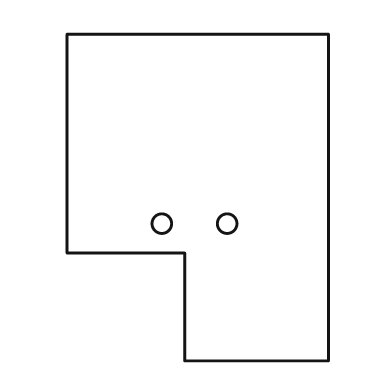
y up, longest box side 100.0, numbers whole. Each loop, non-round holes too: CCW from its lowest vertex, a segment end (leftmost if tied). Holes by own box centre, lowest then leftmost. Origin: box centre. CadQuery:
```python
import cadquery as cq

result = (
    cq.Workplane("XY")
    .moveTo(-4.0, -50.0)
    .lineTo(40.0, -50.0)
    .lineTo(40.0, 50.0)
    .lineTo(-40.0, 50.0)
    .lineTo(-40.0, -17.0)
    .lineTo(-4.0, -17.0)
    .close()
    .moveTo(-11.0, -8.0)
    .circle(3.0)
    .moveTo(9.0, -8.0)
    .circle(3.0)
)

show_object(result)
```